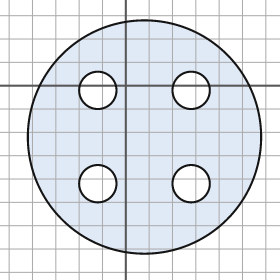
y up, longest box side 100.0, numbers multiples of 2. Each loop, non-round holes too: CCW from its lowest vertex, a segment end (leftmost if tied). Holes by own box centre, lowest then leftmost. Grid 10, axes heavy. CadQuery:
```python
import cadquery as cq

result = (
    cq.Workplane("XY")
    .moveTo(8.0, -22.0)
    .circle(50.0)
    .moveTo(-12.0, -42.0)
    .circle(8.0)
    .moveTo(28.0, -42.0)
    .circle(8.0)
    .moveTo(-12.0, -2.0)
    .circle(8.0)
    .moveTo(28.0, -2.0)
    .circle(8.0)
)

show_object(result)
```